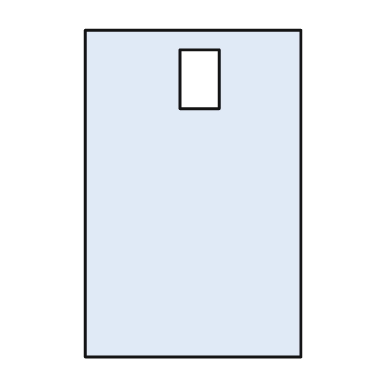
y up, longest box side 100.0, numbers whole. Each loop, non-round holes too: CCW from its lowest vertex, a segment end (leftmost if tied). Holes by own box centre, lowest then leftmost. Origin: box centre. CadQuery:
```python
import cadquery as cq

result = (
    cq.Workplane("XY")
    .moveTo(-33.0, -50.0)
    .lineTo(33.0, -50.0)
    .lineTo(33.0, 50.0)
    .lineTo(-33.0, 50.0)
    .close()
    .moveTo(-4.0, 26.0)
    .lineTo(8.0, 26.0)
    .lineTo(8.0, 44.0)
    .lineTo(-4.0, 44.0)
    .close()
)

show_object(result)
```